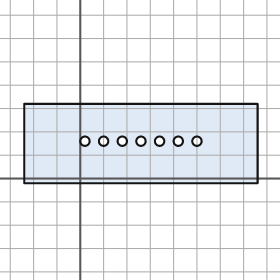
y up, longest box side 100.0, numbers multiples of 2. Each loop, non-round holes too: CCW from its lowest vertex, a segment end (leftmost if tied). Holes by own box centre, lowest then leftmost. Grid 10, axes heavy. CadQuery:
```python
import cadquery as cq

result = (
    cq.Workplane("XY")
    .moveTo(-24.0, -2.0)
    .lineTo(76.0, -2.0)
    .lineTo(76.0, 32.0)
    .lineTo(-24.0, 32.0)
    .close()
    .moveTo(2.0, 16.0)
    .circle(2.0)
    .moveTo(10.0, 16.0)
    .circle(2.0)
    .moveTo(18.0, 16.0)
    .circle(2.0)
    .moveTo(26.0, 16.0)
    .circle(2.0)
    .moveTo(34.0, 16.0)
    .circle(2.0)
    .moveTo(42.0, 16.0)
    .circle(2.0)
    .moveTo(50.0, 16.0)
    .circle(2.0)
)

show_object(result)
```